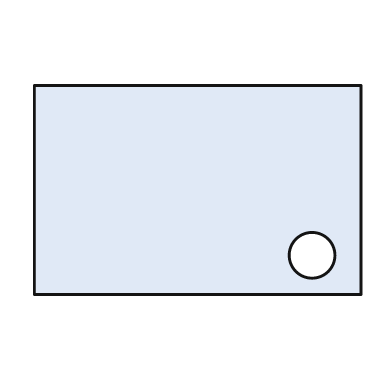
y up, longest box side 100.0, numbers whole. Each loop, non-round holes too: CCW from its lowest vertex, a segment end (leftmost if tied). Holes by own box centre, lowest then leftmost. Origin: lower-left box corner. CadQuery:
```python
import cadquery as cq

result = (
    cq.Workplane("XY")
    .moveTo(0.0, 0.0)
    .lineTo(100.0, 0.0)
    .lineTo(100.0, 64.0)
    .lineTo(0.0, 64.0)
    .close()
    .moveTo(85.0, 12.0)
    .circle(7.0)
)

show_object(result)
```